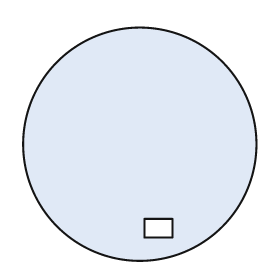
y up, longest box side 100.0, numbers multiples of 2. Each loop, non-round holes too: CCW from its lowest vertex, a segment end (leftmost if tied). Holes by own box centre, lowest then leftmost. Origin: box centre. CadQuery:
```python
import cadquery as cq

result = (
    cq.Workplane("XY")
    .moveTo(0.0, 0.0)
    .circle(50.0)
    .moveTo(2.0, -40.0)
    .lineTo(14.0, -40.0)
    .lineTo(14.0, -32.0)
    .lineTo(2.0, -32.0)
    .close()
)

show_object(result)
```